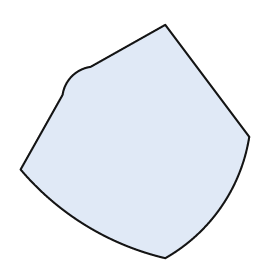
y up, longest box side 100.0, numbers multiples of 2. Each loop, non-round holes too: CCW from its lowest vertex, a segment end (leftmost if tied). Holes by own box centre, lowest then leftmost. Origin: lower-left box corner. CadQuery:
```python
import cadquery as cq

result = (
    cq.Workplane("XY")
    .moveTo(62.0, 0.0)
    .threePointArc((86.0, 22.0), (98.0, 52.0))
    .lineTo(62.0, 100.0)
    .lineTo(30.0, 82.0)
    .threePointArc((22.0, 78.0), (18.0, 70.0))
    .lineTo(0.0, 38.0)
    .threePointArc((28.0, 14.0), (62.0, 0.0))
    .close()
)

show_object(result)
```